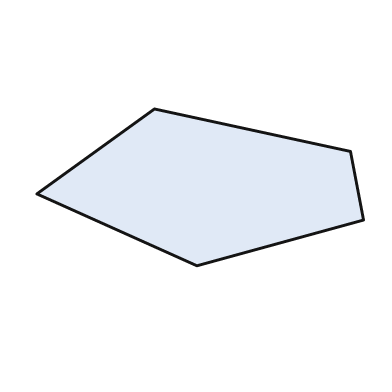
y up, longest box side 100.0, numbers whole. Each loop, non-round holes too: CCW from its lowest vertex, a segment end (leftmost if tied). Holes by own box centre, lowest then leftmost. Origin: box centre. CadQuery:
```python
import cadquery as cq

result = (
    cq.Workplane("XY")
    .moveTo(-1.0, -24.0)
    .lineTo(50.0, -10.0)
    .lineTo(46.0, 11.0)
    .lineTo(-14.0, 24.0)
    .lineTo(-50.0, -2.0)
    .close()
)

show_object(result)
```